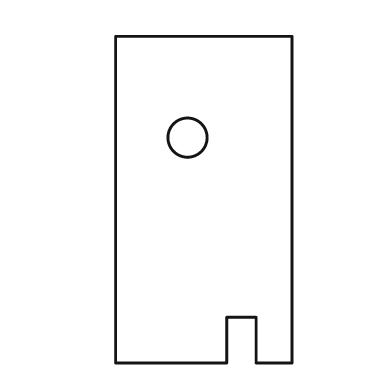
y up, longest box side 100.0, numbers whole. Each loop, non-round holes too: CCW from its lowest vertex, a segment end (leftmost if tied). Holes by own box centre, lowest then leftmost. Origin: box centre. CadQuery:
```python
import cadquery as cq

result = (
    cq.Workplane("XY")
    .moveTo(-27.0, -50.0)
    .lineTo(7.0, -50.0)
    .lineTo(7.0, -36.0)
    .lineTo(16.0, -36.0)
    .lineTo(16.0, -50.0)
    .lineTo(27.0, -50.0)
    .lineTo(27.0, 50.0)
    .lineTo(-27.0, 50.0)
    .close()
    .moveTo(-5.0, 19.0)
    .circle(6.0)
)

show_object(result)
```